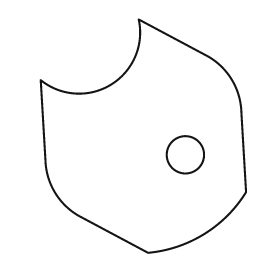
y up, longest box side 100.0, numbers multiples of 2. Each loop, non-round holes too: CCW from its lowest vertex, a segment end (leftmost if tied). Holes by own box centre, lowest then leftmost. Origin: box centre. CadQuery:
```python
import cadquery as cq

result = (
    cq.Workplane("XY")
    .moveTo(2.0, -50.0)
    .threePointArc((26.0, -42.0), (44.0, -24.0))
    .lineTo(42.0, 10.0)
    .threePointArc((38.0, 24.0), (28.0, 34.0))
    .lineTo(-2.0, 50.0)
    .threePointArc((-14.0, 22.0), (-44.0, 24.0))
    .lineTo(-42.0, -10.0)
    .threePointArc((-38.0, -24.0), (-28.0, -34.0))
    .close()
    .moveTo(18.0, -8.0)
    .circle(8.0)
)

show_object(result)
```